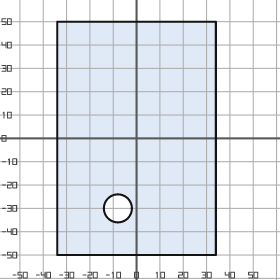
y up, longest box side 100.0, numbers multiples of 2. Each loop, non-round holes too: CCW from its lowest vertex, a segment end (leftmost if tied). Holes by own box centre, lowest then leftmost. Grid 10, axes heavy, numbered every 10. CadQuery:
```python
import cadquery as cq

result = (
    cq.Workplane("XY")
    .moveTo(-34.0, -50.0)
    .lineTo(34.0, -50.0)
    .lineTo(34.0, 50.0)
    .lineTo(-34.0, 50.0)
    .close()
    .moveTo(-8.0, -30.0)
    .circle(6.0)
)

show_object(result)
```